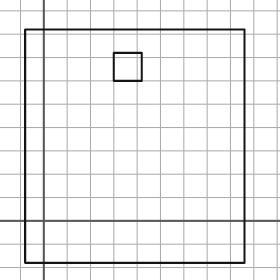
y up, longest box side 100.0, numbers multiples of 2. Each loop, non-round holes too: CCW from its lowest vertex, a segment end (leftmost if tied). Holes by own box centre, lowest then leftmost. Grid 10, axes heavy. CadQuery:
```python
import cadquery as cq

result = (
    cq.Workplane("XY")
    .moveTo(-8.0, -18.0)
    .lineTo(86.0, -18.0)
    .lineTo(86.0, 82.0)
    .lineTo(-8.0, 82.0)
    .close()
    .moveTo(30.0, 60.0)
    .lineTo(42.0, 60.0)
    .lineTo(42.0, 72.0)
    .lineTo(30.0, 72.0)
    .close()
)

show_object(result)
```